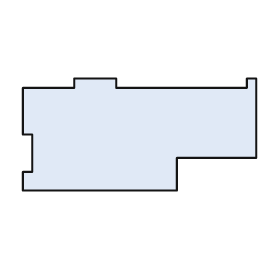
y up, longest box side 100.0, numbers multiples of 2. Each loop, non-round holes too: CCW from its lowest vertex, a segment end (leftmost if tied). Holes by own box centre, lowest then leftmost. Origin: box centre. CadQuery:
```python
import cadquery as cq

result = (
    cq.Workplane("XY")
    .moveTo(-50.0, -24.0)
    .lineTo(16.0, -24.0)
    .lineTo(16.0, -10.0)
    .lineTo(50.0, -10.0)
    .lineTo(50.0, 24.0)
    .lineTo(46.0, 24.0)
    .lineTo(46.0, 20.0)
    .lineTo(-10.0, 20.0)
    .lineTo(-10.0, 24.0)
    .lineTo(-28.0, 24.0)
    .lineTo(-28.0, 20.0)
    .lineTo(-50.0, 20.0)
    .lineTo(-50.0, 0.0)
    .lineTo(-46.0, 0.0)
    .lineTo(-46.0, -16.0)
    .lineTo(-50.0, -16.0)
    .close()
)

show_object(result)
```